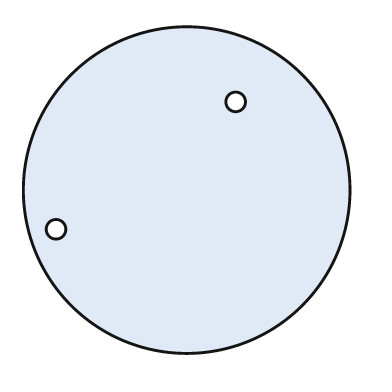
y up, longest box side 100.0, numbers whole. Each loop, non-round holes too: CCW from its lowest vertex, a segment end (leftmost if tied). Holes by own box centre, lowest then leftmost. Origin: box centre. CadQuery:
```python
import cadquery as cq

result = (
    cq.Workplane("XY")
    .moveTo(0.0, 0.0)
    .circle(50.0)
    .moveTo(-40.0, -12.0)
    .circle(3.0)
    .moveTo(15.0, 27.0)
    .circle(3.0)
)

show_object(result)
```